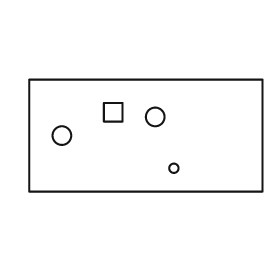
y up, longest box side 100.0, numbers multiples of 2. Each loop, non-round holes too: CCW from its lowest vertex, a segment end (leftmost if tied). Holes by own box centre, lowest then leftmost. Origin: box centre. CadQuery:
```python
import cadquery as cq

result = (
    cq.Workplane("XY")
    .moveTo(-50.0, -24.0)
    .lineTo(50.0, -24.0)
    .lineTo(50.0, 24.0)
    .lineTo(-50.0, 24.0)
    .close()
    .moveTo(12.0, -14.0)
    .circle(2.0)
    .moveTo(-36.0, 0.0)
    .circle(4.0)
    .moveTo(4.0, 8.0)
    .circle(4.0)
    .moveTo(-18.0, 6.0)
    .lineTo(-10.0, 6.0)
    .lineTo(-10.0, 14.0)
    .lineTo(-18.0, 14.0)
    .close()
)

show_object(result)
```